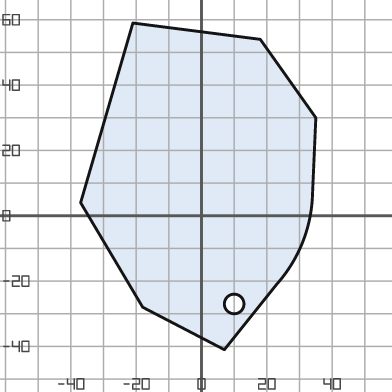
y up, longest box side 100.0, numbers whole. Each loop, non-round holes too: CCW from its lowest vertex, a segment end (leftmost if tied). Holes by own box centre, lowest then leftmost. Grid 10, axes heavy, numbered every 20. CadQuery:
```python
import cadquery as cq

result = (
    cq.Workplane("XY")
    .moveTo(7.0, -41.0)
    .lineTo(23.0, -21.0)
    .threePointArc((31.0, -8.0), (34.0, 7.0))
    .lineTo(35.0, 30.0)
    .lineTo(18.0, 54.0)
    .lineTo(-21.0, 59.0)
    .lineTo(-37.0, 4.0)
    .lineTo(-18.0, -28.0)
    .close()
    .moveTo(10.0, -27.0)
    .circle(3.0)
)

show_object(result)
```